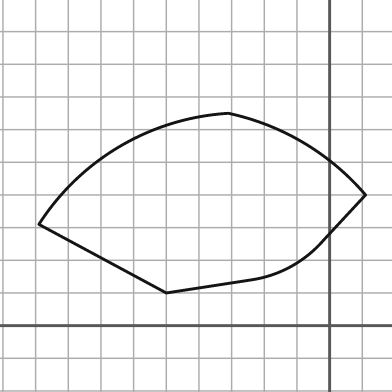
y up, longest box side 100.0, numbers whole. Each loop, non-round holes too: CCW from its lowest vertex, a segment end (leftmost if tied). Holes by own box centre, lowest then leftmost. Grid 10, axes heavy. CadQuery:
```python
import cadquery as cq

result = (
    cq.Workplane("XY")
    .moveTo(-50.0, 10.0)
    .lineTo(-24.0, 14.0)
    .threePointArc((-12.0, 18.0), (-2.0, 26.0))
    .lineTo(11.0, 40.0)
    .threePointArc((-8.0, 56.0), (-31.0, 65.0))
    .threePointArc((-64.0, 55.0), (-89.0, 31.0))
    .close()
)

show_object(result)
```